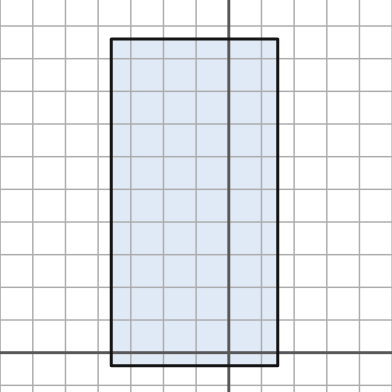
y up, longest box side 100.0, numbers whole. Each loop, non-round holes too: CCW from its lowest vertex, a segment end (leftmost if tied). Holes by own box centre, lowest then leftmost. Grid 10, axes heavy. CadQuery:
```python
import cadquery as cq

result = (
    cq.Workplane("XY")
    .moveTo(-36.0, -4.0)
    .lineTo(15.0, -4.0)
    .lineTo(15.0, 96.0)
    .lineTo(-36.0, 96.0)
    .close()
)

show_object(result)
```